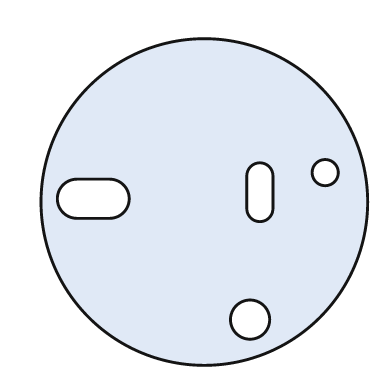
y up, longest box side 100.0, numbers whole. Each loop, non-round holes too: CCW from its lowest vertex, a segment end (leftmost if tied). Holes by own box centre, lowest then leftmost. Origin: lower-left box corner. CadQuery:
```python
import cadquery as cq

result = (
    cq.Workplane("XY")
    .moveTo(50.0, 50.0)
    .circle(50.0)
    .moveTo(64.0, 14.0)
    .circle(6.0)
    .moveTo(11.0, 45.0)
    .lineTo(21.0, 45.0)
    .threePointArc((27.0, 51.0), (21.0, 57.0))
    .lineTo(11.0, 57.0)
    .threePointArc((5.0, 51.0), (11.0, 45.0))
    .close()
    .moveTo(63.0, 48.0)
    .threePointArc((67.0, 44.0), (71.0, 48.0))
    .lineTo(71.0, 58.0)
    .threePointArc((67.0, 62.0), (63.0, 58.0))
    .close()
    .moveTo(87.0, 59.0)
    .circle(4.0)
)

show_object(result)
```